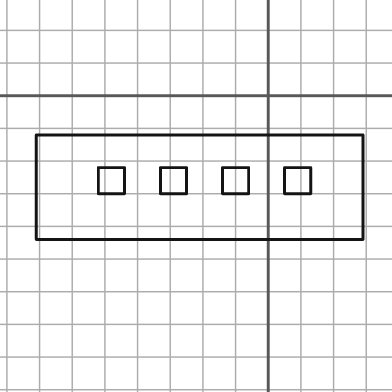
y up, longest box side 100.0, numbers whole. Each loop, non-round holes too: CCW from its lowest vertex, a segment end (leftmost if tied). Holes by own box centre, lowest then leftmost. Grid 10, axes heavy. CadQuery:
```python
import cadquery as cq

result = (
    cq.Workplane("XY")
    .moveTo(-71.0, -44.0)
    .lineTo(29.0, -44.0)
    .lineTo(29.0, -12.0)
    .lineTo(-71.0, -12.0)
    .close()
    .moveTo(-52.0, -30.0)
    .lineTo(-44.0, -30.0)
    .lineTo(-44.0, -22.0)
    .lineTo(-52.0, -22.0)
    .close()
    .moveTo(-33.0, -30.0)
    .lineTo(-25.0, -30.0)
    .lineTo(-25.0, -22.0)
    .lineTo(-33.0, -22.0)
    .close()
    .moveTo(-14.0, -30.0)
    .lineTo(-6.0, -30.0)
    .lineTo(-6.0, -22.0)
    .lineTo(-14.0, -22.0)
    .close()
    .moveTo(5.0, -30.0)
    .lineTo(13.0, -30.0)
    .lineTo(13.0, -22.0)
    .lineTo(5.0, -22.0)
    .close()
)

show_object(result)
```